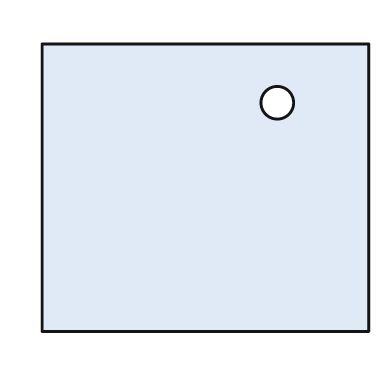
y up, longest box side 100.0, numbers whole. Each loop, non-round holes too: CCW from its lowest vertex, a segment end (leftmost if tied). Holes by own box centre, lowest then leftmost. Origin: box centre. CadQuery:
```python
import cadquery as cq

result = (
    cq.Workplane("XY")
    .moveTo(-50.0, -44.0)
    .lineTo(50.0, -44.0)
    .lineTo(50.0, 44.0)
    .lineTo(-50.0, 44.0)
    .close()
    .moveTo(22.0, 26.0)
    .circle(5.0)
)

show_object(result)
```